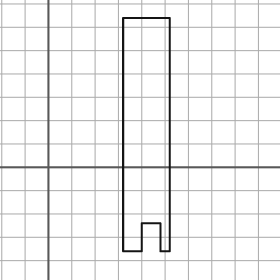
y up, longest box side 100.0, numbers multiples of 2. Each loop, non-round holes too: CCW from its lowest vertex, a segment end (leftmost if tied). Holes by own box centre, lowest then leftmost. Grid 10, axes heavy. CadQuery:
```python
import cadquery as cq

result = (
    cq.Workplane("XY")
    .moveTo(32.0, -36.0)
    .lineTo(40.0, -36.0)
    .lineTo(40.0, -24.0)
    .lineTo(48.0, -24.0)
    .lineTo(48.0, -36.0)
    .lineTo(52.0, -36.0)
    .lineTo(52.0, 64.0)
    .lineTo(32.0, 64.0)
    .close()
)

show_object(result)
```